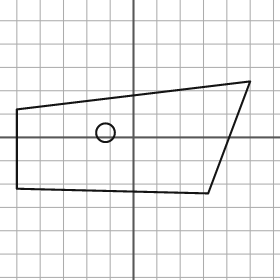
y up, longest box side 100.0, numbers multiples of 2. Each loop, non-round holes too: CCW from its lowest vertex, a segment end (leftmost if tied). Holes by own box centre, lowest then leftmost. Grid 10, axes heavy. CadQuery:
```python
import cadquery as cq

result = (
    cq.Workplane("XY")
    .moveTo(32.0, -24.0)
    .lineTo(50.0, 24.0)
    .lineTo(-50.0, 12.0)
    .lineTo(-50.0, -22.0)
    .close()
    .moveTo(-12.0, 2.0)
    .circle(4.0)
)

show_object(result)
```